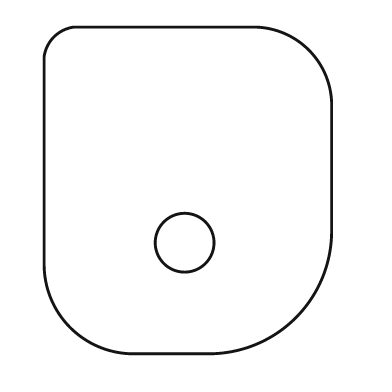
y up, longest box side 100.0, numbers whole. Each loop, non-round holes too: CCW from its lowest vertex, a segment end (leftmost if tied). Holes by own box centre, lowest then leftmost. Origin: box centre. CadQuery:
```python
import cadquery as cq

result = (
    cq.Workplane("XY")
    .moveTo(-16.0, -50.0)
    .lineTo(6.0, -50.0)
    .threePointArc((33.0, -39.0), (44.0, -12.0))
    .lineTo(44.0, 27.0)
    .threePointArc((37.0, 43.0), (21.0, 50.0))
    .lineTo(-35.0, 50.0)
    .threePointArc((-41.0, 47.0), (-44.0, 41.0))
    .lineTo(-44.0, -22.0)
    .threePointArc((-36.0, -42.0), (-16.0, -50.0))
    .close()
    .moveTo(-1.0, -16.0)
    .circle(9.0)
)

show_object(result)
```